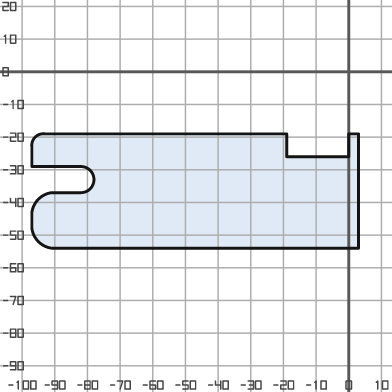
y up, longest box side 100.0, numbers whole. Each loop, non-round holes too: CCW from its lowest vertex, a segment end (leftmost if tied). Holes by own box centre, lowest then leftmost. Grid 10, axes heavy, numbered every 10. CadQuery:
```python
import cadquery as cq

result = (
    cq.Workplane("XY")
    .moveTo(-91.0, -54.0)
    .lineTo(3.0, -54.0)
    .lineTo(3.0, -19.0)
    .lineTo(0.0, -19.0)
    .lineTo(0.0, -26.0)
    .lineTo(-19.0, -26.0)
    .lineTo(-19.0, -19.0)
    .lineTo(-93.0, -19.0)
    .threePointArc((-96.0, -20.0), (-97.0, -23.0))
    .lineTo(-97.0, -29.0)
    .lineTo(-82.0, -29.0)
    .threePointArc((-78.0, -33.0), (-82.0, -37.0))
    .lineTo(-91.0, -37.0)
    .threePointArc((-95.0, -39.0), (-97.0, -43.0))
    .lineTo(-97.0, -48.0)
    .threePointArc((-95.0, -52.0), (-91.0, -54.0))
    .close()
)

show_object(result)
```